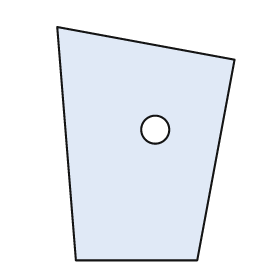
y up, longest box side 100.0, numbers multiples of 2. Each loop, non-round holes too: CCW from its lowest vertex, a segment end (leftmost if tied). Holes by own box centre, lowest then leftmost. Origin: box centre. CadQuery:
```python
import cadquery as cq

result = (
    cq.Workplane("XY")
    .moveTo(-30.0, -50.0)
    .lineTo(22.0, -50.0)
    .lineTo(38.0, 36.0)
    .lineTo(-38.0, 50.0)
    .close()
    .moveTo(4.0, 6.0)
    .circle(6.0)
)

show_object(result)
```